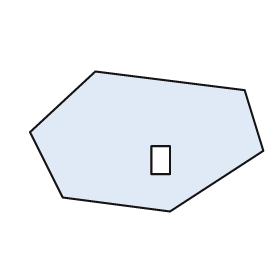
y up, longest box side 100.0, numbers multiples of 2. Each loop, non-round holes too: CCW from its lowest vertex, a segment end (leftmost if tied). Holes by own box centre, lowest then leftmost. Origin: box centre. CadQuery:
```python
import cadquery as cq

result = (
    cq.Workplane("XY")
    .moveTo(10.0, -30.0)
    .lineTo(50.0, -4.0)
    .lineTo(42.0, 22.0)
    .lineTo(-22.0, 30.0)
    .lineTo(-50.0, 4.0)
    .lineTo(-36.0, -24.0)
    .close()
    .moveTo(2.0, -14.0)
    .lineTo(10.0, -14.0)
    .lineTo(10.0, -2.0)
    .lineTo(2.0, -2.0)
    .close()
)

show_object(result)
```